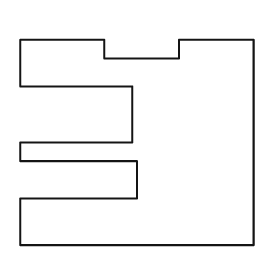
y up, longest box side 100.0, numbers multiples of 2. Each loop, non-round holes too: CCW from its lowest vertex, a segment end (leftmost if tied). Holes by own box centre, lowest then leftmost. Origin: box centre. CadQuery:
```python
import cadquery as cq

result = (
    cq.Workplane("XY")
    .moveTo(-50.0, -44.0)
    .lineTo(50.0, -44.0)
    .lineTo(50.0, 44.0)
    .lineTo(18.0, 44.0)
    .lineTo(18.0, 36.0)
    .lineTo(-14.0, 36.0)
    .lineTo(-14.0, 44.0)
    .lineTo(-50.0, 44.0)
    .lineTo(-50.0, 24.0)
    .lineTo(-2.0, 24.0)
    .lineTo(-2.0, 0.0)
    .lineTo(-50.0, 0.0)
    .lineTo(-50.0, -8.0)
    .lineTo(0.0, -8.0)
    .lineTo(0.0, -24.0)
    .lineTo(-50.0, -24.0)
    .close()
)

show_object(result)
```